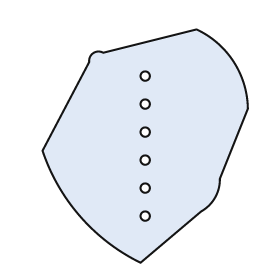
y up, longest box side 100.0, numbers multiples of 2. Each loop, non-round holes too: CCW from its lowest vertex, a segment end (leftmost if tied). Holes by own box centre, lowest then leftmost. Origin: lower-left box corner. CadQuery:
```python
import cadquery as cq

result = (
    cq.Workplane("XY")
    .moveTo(42.0, 0.0)
    .lineTo(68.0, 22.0)
    .threePointArc((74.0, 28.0), (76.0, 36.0))
    .lineTo(88.0, 66.0)
    .threePointArc((82.0, 86.0), (66.0, 100.0))
    .lineTo(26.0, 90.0)
    .threePointArc((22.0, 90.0), (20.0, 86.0))
    .lineTo(0.0, 48.0)
    .threePointArc((16.0, 20.0), (42.0, 0.0))
    .close()
    .moveTo(44.0, 20.0)
    .circle(2.0)
    .moveTo(44.0, 32.0)
    .circle(2.0)
    .moveTo(44.0, 44.0)
    .circle(2.0)
    .moveTo(44.0, 56.0)
    .circle(2.0)
    .moveTo(44.0, 68.0)
    .circle(2.0)
    .moveTo(44.0, 80.0)
    .circle(2.0)
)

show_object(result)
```